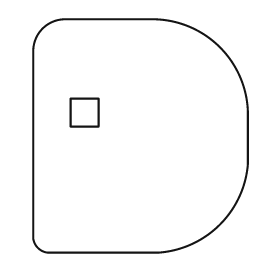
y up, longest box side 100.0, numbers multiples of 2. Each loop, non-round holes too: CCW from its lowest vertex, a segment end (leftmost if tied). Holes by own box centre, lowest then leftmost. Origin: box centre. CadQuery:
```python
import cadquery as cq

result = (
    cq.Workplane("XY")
    .moveTo(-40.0, -50.0)
    .lineTo(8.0, -50.0)
    .threePointArc((34.0, -38.0), (46.0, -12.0))
    .lineTo(46.0, 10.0)
    .threePointArc((34.0, 38.0), (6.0, 50.0))
    .lineTo(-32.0, 50.0)
    .threePointArc((-42.0, 46.0), (-46.0, 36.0))
    .lineTo(-46.0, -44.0)
    .threePointArc((-44.0, -48.0), (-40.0, -50.0))
    .close()
    .moveTo(-30.0, 4.0)
    .lineTo(-18.0, 4.0)
    .lineTo(-18.0, 16.0)
    .lineTo(-30.0, 16.0)
    .close()
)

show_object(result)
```